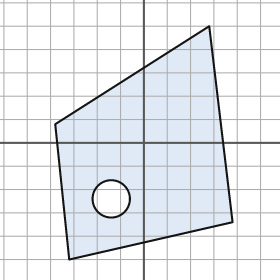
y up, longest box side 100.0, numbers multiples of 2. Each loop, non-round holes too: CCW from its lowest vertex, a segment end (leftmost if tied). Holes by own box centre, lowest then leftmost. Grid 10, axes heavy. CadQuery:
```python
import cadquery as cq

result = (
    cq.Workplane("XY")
    .moveTo(-32.0, -50.0)
    .lineTo(38.0, -34.0)
    .lineTo(28.0, 50.0)
    .lineTo(-38.0, 8.0)
    .close()
    .moveTo(-14.0, -24.0)
    .circle(8.0)
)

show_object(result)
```